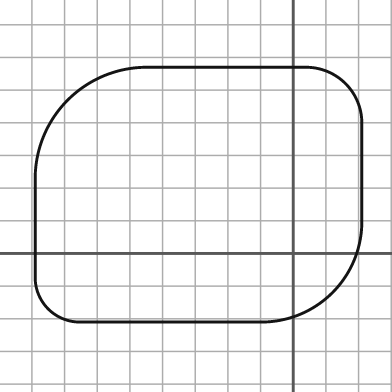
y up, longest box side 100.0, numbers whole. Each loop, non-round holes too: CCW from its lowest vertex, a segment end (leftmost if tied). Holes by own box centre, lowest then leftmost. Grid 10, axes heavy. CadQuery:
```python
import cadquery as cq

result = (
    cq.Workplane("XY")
    .moveTo(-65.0, -21.0)
    .lineTo(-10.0, -21.0)
    .threePointArc((12.0, -12.0), (21.0, 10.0))
    .lineTo(21.0, 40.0)
    .threePointArc((16.0, 52.0), (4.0, 57.0))
    .lineTo(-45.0, 57.0)
    .threePointArc((-69.0, 47.0), (-79.0, 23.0))
    .lineTo(-79.0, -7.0)
    .threePointArc((-75.0, -17.0), (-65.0, -21.0))
    .close()
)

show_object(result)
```